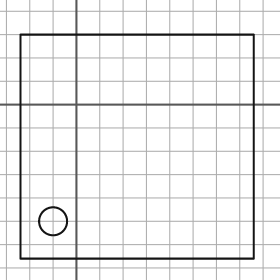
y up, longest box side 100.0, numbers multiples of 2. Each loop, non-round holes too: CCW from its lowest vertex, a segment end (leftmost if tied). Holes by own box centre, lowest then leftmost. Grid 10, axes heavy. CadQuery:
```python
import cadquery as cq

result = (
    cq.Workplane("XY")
    .moveTo(-24.0, -66.0)
    .lineTo(76.0, -66.0)
    .lineTo(76.0, 30.0)
    .lineTo(-24.0, 30.0)
    .close()
    .moveTo(-10.0, -50.0)
    .circle(6.0)
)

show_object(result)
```